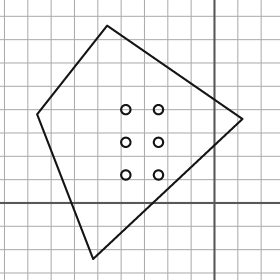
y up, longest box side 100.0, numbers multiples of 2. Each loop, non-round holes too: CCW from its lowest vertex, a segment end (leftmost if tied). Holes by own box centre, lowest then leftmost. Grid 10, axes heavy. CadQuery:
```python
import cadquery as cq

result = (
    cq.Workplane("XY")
    .moveTo(-52.0, -24.0)
    .lineTo(12.0, 36.0)
    .lineTo(-46.0, 76.0)
    .lineTo(-76.0, 38.0)
    .close()
    .moveTo(-38.0, 12.0)
    .circle(2.0)
    .moveTo(-24.0, 12.0)
    .circle(2.0)
    .moveTo(-38.0, 26.0)
    .circle(2.0)
    .moveTo(-24.0, 26.0)
    .circle(2.0)
    .moveTo(-38.0, 40.0)
    .circle(2.0)
    .moveTo(-24.0, 40.0)
    .circle(2.0)
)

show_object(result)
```